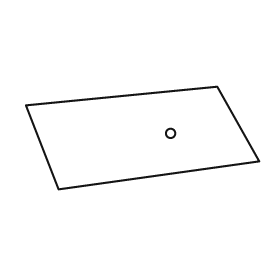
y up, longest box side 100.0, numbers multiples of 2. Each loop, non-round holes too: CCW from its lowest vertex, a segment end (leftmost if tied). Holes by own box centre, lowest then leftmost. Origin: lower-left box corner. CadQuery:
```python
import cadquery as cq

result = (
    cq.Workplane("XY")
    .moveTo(14.0, 0.0)
    .lineTo(100.0, 12.0)
    .lineTo(82.0, 44.0)
    .lineTo(0.0, 36.0)
    .close()
    .moveTo(62.0, 24.0)
    .circle(2.0)
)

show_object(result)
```